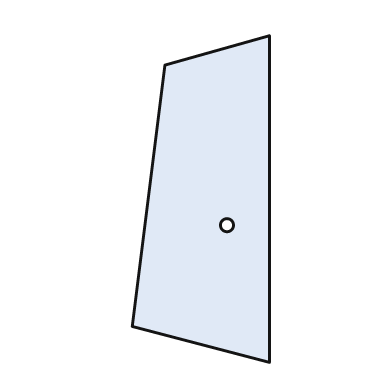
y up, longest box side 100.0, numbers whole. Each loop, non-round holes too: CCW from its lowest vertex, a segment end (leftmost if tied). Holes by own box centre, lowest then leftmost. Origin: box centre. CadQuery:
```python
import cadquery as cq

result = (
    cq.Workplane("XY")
    .moveTo(21.0, -50.0)
    .lineTo(21.0, 50.0)
    .lineTo(-11.0, 41.0)
    .lineTo(-21.0, -39.0)
    .close()
    .moveTo(8.0, -8.0)
    .circle(2.0)
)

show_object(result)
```